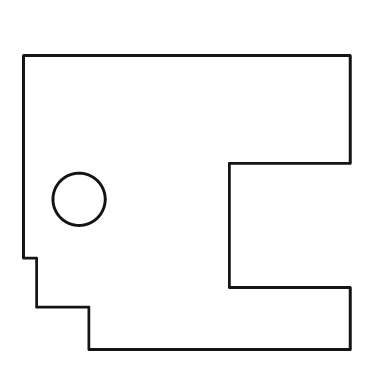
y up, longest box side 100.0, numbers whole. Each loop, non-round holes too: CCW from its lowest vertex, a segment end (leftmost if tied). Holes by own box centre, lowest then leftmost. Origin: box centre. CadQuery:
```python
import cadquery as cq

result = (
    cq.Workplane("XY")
    .moveTo(-30.0, -45.0)
    .lineTo(50.0, -45.0)
    .lineTo(50.0, -26.0)
    .lineTo(13.0, -26.0)
    .lineTo(13.0, 12.0)
    .lineTo(50.0, 12.0)
    .lineTo(50.0, 45.0)
    .lineTo(-50.0, 45.0)
    .lineTo(-50.0, -17.0)
    .lineTo(-46.0, -17.0)
    .lineTo(-46.0, -32.0)
    .lineTo(-30.0, -32.0)
    .close()
    .moveTo(-33.0, 1.0)
    .circle(8.0)
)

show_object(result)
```